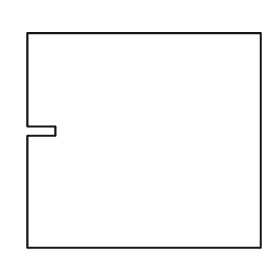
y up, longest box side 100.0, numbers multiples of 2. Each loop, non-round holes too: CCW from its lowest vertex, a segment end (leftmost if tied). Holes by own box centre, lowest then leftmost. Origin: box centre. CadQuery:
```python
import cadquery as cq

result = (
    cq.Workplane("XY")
    .moveTo(-50.0, -46.0)
    .lineTo(50.0, -46.0)
    .lineTo(50.0, 46.0)
    .lineTo(-50.0, 46.0)
    .lineTo(-50.0, 6.0)
    .lineTo(-38.0, 6.0)
    .lineTo(-38.0, 2.0)
    .lineTo(-50.0, 2.0)
    .close()
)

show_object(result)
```